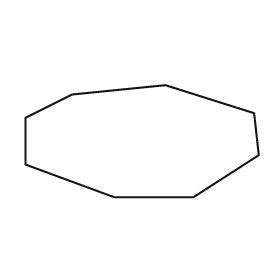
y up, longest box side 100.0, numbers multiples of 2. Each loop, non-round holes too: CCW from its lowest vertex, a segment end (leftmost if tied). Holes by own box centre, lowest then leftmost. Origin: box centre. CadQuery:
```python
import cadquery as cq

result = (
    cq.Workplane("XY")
    .moveTo(-12.0, -24.0)
    .lineTo(22.0, -24.0)
    .lineTo(50.0, -6.0)
    .lineTo(48.0, 12.0)
    .lineTo(10.0, 24.0)
    .lineTo(-30.0, 20.0)
    .lineTo(-50.0, 10.0)
    .lineTo(-50.0, -10.0)
    .close()
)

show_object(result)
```